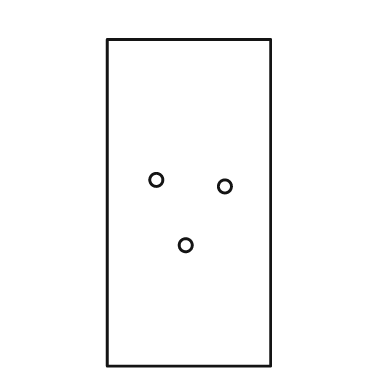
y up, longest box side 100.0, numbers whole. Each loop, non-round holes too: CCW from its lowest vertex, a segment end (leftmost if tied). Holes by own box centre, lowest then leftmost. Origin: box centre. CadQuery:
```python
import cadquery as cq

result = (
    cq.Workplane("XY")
    .moveTo(-25.0, -50.0)
    .lineTo(25.0, -50.0)
    .lineTo(25.0, 50.0)
    .lineTo(-25.0, 50.0)
    .close()
    .moveTo(-1.0, -13.0)
    .circle(2.0)
    .moveTo(11.0, 5.0)
    .circle(2.0)
    .moveTo(-10.0, 7.0)
    .circle(2.0)
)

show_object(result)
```